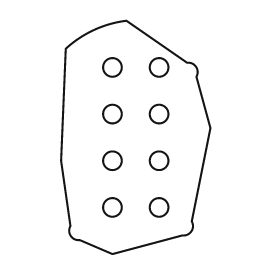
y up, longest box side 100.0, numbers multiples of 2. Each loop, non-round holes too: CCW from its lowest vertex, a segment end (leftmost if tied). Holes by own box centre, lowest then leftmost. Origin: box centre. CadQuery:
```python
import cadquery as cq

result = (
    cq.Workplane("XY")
    .moveTo(-10.0, -50.0)
    .lineTo(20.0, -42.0)
    .threePointArc((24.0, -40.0), (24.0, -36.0))
    .lineTo(32.0, 4.0)
    .lineTo(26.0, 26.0)
    .threePointArc((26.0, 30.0), (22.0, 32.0))
    .lineTo(-4.0, 50.0)
    .threePointArc((-18.0, 46.0), (-30.0, 38.0))
    .lineTo(-32.0, -10.0)
    .lineTo(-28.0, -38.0)
    .threePointArc((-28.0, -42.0), (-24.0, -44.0))
    .close()
    .moveTo(-10.0, -30.0)
    .circle(4.0)
    .moveTo(10.0, -30.0)
    .circle(4.0)
    .moveTo(-10.0, -10.0)
    .circle(4.0)
    .moveTo(10.0, -10.0)
    .circle(4.0)
    .moveTo(-10.0, 10.0)
    .circle(4.0)
    .moveTo(10.0, 10.0)
    .circle(4.0)
    .moveTo(-10.0, 30.0)
    .circle(4.0)
    .moveTo(10.0, 30.0)
    .circle(4.0)
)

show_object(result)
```